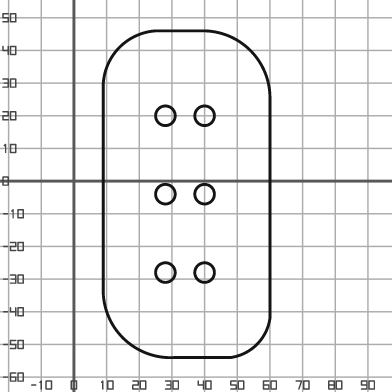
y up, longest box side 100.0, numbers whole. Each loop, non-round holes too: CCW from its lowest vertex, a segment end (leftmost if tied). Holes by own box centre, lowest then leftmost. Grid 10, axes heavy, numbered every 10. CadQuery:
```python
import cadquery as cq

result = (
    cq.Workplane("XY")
    .moveTo(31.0, -54.0)
    .lineTo(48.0, -54.0)
    .threePointArc((56.0, -50.0), (60.0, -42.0))
    .lineTo(60.0, 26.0)
    .threePointArc((54.0, 40.0), (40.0, 46.0))
    .lineTo(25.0, 46.0)
    .threePointArc((14.0, 41.0), (9.0, 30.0))
    .lineTo(9.0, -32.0)
    .threePointArc((15.0, -48.0), (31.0, -54.0))
    .close()
    .moveTo(28.0, -28.0)
    .circle(3.0)
    .moveTo(40.0, -28.0)
    .circle(3.0)
    .moveTo(28.0, -4.0)
    .circle(3.0)
    .moveTo(40.0, -4.0)
    .circle(3.0)
    .moveTo(28.0, 20.0)
    .circle(3.0)
    .moveTo(40.0, 20.0)
    .circle(3.0)
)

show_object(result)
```